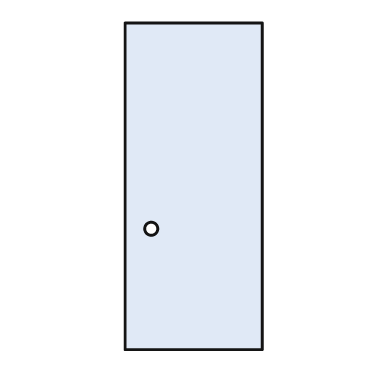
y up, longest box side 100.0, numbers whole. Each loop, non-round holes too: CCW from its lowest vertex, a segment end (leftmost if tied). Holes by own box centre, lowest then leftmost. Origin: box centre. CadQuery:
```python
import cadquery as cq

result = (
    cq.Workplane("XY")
    .moveTo(-21.0, -50.0)
    .lineTo(21.0, -50.0)
    .lineTo(21.0, 50.0)
    .lineTo(-21.0, 50.0)
    .close()
    .moveTo(-13.0, -13.0)
    .circle(2.0)
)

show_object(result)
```